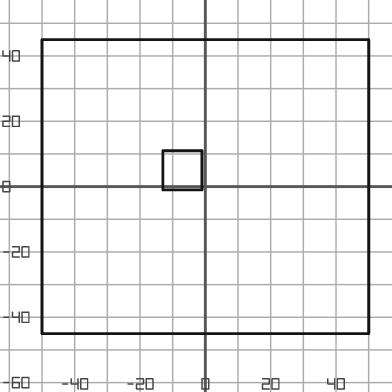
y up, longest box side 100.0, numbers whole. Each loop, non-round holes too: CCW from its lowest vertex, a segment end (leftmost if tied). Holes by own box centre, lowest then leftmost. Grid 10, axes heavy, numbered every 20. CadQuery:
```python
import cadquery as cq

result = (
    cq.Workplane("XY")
    .moveTo(-50.0, -45.0)
    .lineTo(50.0, -45.0)
    .lineTo(50.0, 45.0)
    .lineTo(-50.0, 45.0)
    .close()
    .moveTo(-13.0, -1.0)
    .lineTo(-1.0, -1.0)
    .lineTo(-1.0, 11.0)
    .lineTo(-13.0, 11.0)
    .close()
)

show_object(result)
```